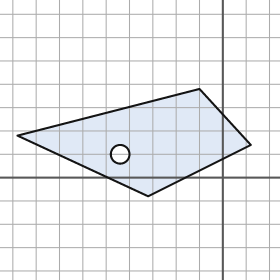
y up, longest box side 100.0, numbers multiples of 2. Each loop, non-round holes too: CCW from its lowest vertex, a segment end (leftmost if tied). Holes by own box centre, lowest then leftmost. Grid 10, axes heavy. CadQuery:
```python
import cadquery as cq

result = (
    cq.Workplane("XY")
    .moveTo(-32.0, -8.0)
    .lineTo(12.0, 14.0)
    .lineTo(-10.0, 38.0)
    .lineTo(-88.0, 18.0)
    .close()
    .moveTo(-44.0, 10.0)
    .circle(4.0)
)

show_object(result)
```